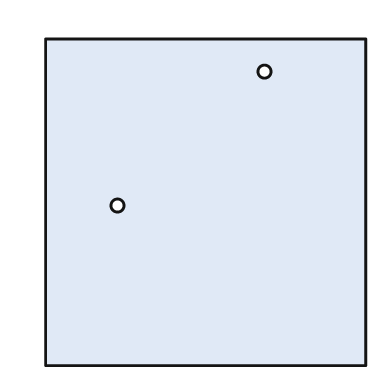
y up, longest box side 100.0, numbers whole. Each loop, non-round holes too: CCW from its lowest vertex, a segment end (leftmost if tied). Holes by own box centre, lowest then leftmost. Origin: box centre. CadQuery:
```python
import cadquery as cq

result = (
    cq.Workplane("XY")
    .moveTo(-49.0, -50.0)
    .lineTo(49.0, -50.0)
    .lineTo(49.0, 50.0)
    .lineTo(-49.0, 50.0)
    .close()
    .moveTo(-27.0, -1.0)
    .circle(2.0)
    .moveTo(18.0, 40.0)
    .circle(2.0)
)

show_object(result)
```